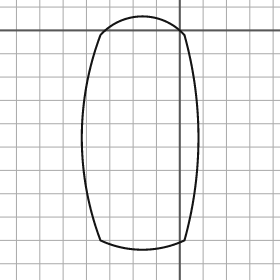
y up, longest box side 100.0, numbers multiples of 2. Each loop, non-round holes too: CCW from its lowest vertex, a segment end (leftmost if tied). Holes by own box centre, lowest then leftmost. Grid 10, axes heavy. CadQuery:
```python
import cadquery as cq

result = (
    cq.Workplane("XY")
    .moveTo(-34.0, -90.0)
    .threePointArc((-16.0, -94.0), (2.0, -90.0))
    .threePointArc((8.0, -46.0), (2.0, -2.0))
    .threePointArc((-16.0, 6.0), (-34.0, -2.0))
    .threePointArc((-42.0, -46.0), (-34.0, -90.0))
    .close()
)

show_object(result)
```